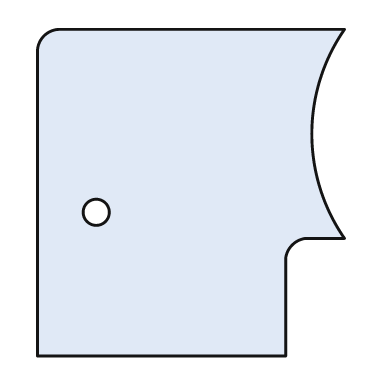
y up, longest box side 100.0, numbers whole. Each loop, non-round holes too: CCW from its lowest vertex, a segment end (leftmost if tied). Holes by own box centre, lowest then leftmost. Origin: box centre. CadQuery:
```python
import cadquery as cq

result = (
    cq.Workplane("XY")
    .moveTo(-47.0, -50.0)
    .lineTo(29.0, -50.0)
    .lineTo(29.0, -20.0)
    .threePointArc((31.0, -16.0), (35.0, -14.0))
    .lineTo(47.0, -14.0)
    .threePointArc((37.0, 18.0), (47.0, 50.0))
    .lineTo(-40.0, 50.0)
    .threePointArc((-45.0, 48.0), (-47.0, 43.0))
    .close()
    .moveTo(-29.0, -6.0)
    .circle(4.0)
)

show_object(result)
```